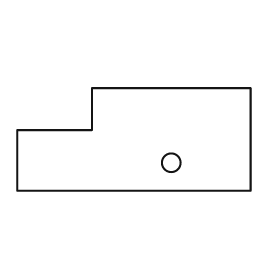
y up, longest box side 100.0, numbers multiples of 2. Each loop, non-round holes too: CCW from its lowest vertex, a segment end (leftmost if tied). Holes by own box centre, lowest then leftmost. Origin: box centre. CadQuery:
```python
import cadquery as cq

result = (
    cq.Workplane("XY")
    .moveTo(-50.0, -22.0)
    .lineTo(50.0, -22.0)
    .lineTo(50.0, 22.0)
    .lineTo(-18.0, 22.0)
    .lineTo(-18.0, 4.0)
    .lineTo(-50.0, 4.0)
    .close()
    .moveTo(16.0, -10.0)
    .circle(4.0)
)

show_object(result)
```